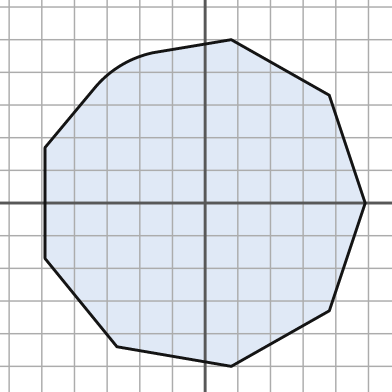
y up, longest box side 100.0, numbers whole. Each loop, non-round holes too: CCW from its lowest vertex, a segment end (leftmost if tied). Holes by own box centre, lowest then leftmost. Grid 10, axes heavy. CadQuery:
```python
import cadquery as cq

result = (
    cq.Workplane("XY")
    .moveTo(8.0, -50.0)
    .lineTo(38.0, -33.0)
    .lineTo(49.0, 0.0)
    .lineTo(38.0, 33.0)
    .lineTo(8.0, 50.0)
    .lineTo(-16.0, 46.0)
    .threePointArc((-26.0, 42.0), (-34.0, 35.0))
    .lineTo(-49.0, 17.0)
    .lineTo(-49.0, -17.0)
    .lineTo(-27.0, -44.0)
    .close()
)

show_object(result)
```